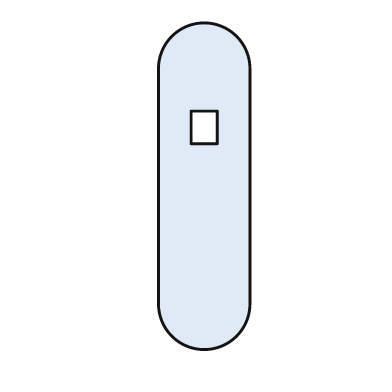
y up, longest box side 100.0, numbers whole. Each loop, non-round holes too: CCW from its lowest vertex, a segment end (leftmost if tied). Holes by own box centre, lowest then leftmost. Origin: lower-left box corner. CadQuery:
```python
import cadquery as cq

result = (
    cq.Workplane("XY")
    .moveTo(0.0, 14.0)
    .threePointArc((14.0, 0.0), (28.0, 14.0))
    .lineTo(28.0, 86.0)
    .threePointArc((14.0, 100.0), (0.0, 86.0))
    .close()
    .moveTo(10.0, 63.0)
    .lineTo(18.0, 63.0)
    .lineTo(18.0, 73.0)
    .lineTo(10.0, 73.0)
    .close()
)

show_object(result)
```